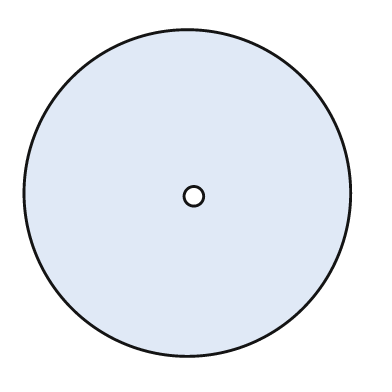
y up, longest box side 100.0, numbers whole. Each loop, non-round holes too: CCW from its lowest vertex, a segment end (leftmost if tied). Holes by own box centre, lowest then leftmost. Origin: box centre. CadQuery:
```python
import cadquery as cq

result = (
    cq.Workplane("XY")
    .moveTo(0.0, 0.0)
    .circle(50.0)
    .moveTo(2.0, -1.0)
    .circle(3.0)
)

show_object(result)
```